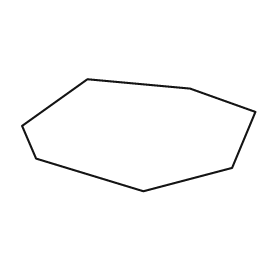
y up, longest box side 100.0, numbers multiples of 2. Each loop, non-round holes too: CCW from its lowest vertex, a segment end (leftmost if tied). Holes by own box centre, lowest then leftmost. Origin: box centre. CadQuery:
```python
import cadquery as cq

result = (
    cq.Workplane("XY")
    .moveTo(2.0, -24.0)
    .lineTo(40.0, -14.0)
    .lineTo(50.0, 10.0)
    .lineTo(22.0, 20.0)
    .lineTo(-22.0, 24.0)
    .lineTo(-50.0, 4.0)
    .lineTo(-44.0, -10.0)
    .close()
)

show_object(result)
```